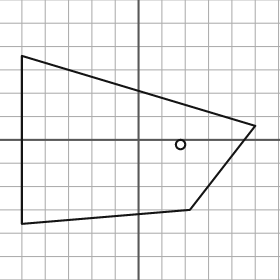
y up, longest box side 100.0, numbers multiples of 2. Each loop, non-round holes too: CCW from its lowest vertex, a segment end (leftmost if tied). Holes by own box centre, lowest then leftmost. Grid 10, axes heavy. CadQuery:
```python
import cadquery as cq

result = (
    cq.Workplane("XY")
    .moveTo(-50.0, -36.0)
    .lineTo(22.0, -30.0)
    .lineTo(50.0, 6.0)
    .lineTo(-50.0, 36.0)
    .close()
    .moveTo(18.0, -2.0)
    .circle(2.0)
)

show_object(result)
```